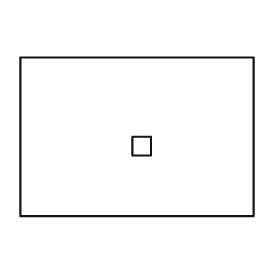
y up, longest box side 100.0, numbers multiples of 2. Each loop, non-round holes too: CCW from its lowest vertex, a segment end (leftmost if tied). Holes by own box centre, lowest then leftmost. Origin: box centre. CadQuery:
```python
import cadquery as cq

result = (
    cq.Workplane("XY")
    .moveTo(-50.0, -34.0)
    .lineTo(50.0, -34.0)
    .lineTo(50.0, 34.0)
    .lineTo(-50.0, 34.0)
    .close()
    .moveTo(-2.0, -8.0)
    .lineTo(6.0, -8.0)
    .lineTo(6.0, 0.0)
    .lineTo(-2.0, 0.0)
    .close()
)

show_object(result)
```